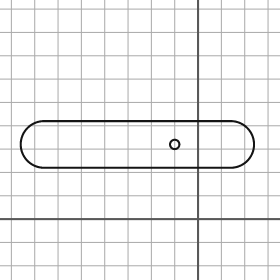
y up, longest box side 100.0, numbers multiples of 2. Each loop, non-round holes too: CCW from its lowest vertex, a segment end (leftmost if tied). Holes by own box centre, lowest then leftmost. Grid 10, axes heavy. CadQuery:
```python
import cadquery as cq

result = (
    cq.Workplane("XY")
    .moveTo(-66.0, 22.0)
    .lineTo(14.0, 22.0)
    .threePointArc((24.0, 32.0), (14.0, 42.0))
    .lineTo(-66.0, 42.0)
    .threePointArc((-76.0, 32.0), (-66.0, 22.0))
    .close()
    .moveTo(-10.0, 32.0)
    .circle(2.0)
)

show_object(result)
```